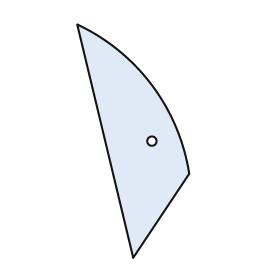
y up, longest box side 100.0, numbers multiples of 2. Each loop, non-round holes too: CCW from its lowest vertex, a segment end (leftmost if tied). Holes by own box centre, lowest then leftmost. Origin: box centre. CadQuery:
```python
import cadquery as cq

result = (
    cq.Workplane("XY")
    .moveTo(0.0, -50.0)
    .lineTo(24.0, -14.0)
    .threePointArc((8.0, 24.0), (-24.0, 50.0))
    .close()
    .moveTo(8.0, 0.0)
    .circle(2.0)
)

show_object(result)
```